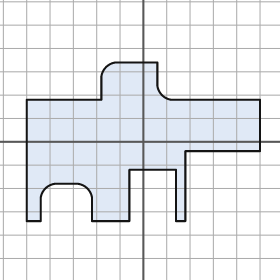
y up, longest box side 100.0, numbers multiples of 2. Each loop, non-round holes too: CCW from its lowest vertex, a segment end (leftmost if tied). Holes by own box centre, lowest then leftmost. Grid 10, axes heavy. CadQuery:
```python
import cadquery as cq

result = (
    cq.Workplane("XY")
    .moveTo(-50.0, -34.0)
    .lineTo(-44.0, -34.0)
    .lineTo(-44.0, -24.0)
    .threePointArc((-42.0, -20.0), (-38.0, -18.0))
    .lineTo(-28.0, -18.0)
    .threePointArc((-24.0, -20.0), (-22.0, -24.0))
    .lineTo(-22.0, -34.0)
    .lineTo(-6.0, -34.0)
    .lineTo(-6.0, -12.0)
    .lineTo(14.0, -12.0)
    .lineTo(14.0, -34.0)
    .lineTo(18.0, -34.0)
    .lineTo(18.0, -4.0)
    .lineTo(50.0, -4.0)
    .lineTo(50.0, 18.0)
    .lineTo(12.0, 18.0)
    .threePointArc((8.0, 20.0), (6.0, 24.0))
    .lineTo(6.0, 34.0)
    .lineTo(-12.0, 34.0)
    .threePointArc((-16.0, 32.0), (-18.0, 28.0))
    .lineTo(-18.0, 18.0)
    .lineTo(-50.0, 18.0)
    .close()
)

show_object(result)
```